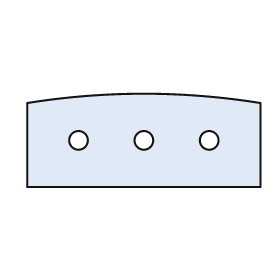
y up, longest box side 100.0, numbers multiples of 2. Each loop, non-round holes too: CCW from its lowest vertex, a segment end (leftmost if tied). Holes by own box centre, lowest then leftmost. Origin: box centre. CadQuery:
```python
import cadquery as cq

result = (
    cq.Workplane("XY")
    .moveTo(-50.0, -20.0)
    .lineTo(50.0, -20.0)
    .lineTo(50.0, 16.0)
    .threePointArc((0.0, 20.0), (-50.0, 16.0))
    .close()
    .moveTo(-28.0, 0.0)
    .circle(4.0)
    .moveTo(0.0, 0.0)
    .circle(4.0)
    .moveTo(28.0, 0.0)
    .circle(4.0)
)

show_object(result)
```